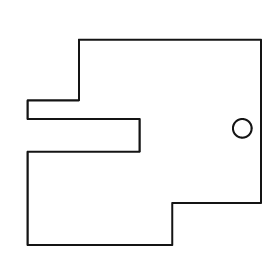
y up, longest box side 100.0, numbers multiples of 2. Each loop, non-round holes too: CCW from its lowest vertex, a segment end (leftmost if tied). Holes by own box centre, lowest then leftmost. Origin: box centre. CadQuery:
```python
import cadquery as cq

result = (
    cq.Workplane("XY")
    .moveTo(-50.0, -44.0)
    .lineTo(12.0, -44.0)
    .lineTo(12.0, -26.0)
    .lineTo(50.0, -26.0)
    .lineTo(50.0, 44.0)
    .lineTo(-28.0, 44.0)
    .lineTo(-28.0, 18.0)
    .lineTo(-50.0, 18.0)
    .lineTo(-50.0, 10.0)
    .lineTo(-2.0, 10.0)
    .lineTo(-2.0, -4.0)
    .lineTo(-50.0, -4.0)
    .close()
    .moveTo(42.0, 6.0)
    .circle(4.0)
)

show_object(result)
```